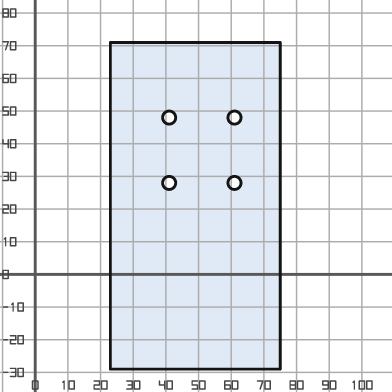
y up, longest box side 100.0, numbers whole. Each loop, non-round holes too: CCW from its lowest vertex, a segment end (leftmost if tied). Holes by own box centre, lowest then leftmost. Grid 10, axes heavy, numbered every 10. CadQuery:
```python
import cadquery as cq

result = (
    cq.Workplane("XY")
    .moveTo(23.0, -29.0)
    .lineTo(75.0, -29.0)
    .lineTo(75.0, 71.0)
    .lineTo(23.0, 71.0)
    .close()
    .moveTo(41.0, 28.0)
    .circle(2.0)
    .moveTo(61.0, 28.0)
    .circle(2.0)
    .moveTo(41.0, 48.0)
    .circle(2.0)
    .moveTo(61.0, 48.0)
    .circle(2.0)
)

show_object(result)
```